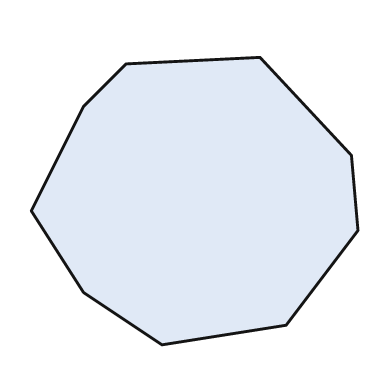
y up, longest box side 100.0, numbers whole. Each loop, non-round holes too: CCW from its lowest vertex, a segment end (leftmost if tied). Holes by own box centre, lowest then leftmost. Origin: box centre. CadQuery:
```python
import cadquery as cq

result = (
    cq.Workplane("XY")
    .moveTo(-10.0, -44.0)
    .lineTo(28.0, -38.0)
    .lineTo(50.0, -9.0)
    .lineTo(48.0, 14.0)
    .lineTo(20.0, 44.0)
    .lineTo(-21.0, 42.0)
    .lineTo(-34.0, 29.0)
    .lineTo(-50.0, -3.0)
    .lineTo(-34.0, -28.0)
    .close()
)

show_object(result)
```